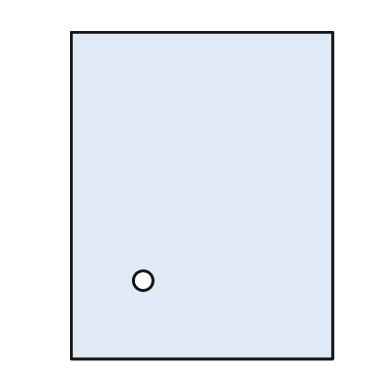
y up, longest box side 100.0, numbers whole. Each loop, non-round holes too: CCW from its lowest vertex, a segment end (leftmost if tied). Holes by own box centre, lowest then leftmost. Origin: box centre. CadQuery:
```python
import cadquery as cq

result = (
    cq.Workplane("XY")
    .moveTo(-40.0, -50.0)
    .lineTo(40.0, -50.0)
    .lineTo(40.0, 50.0)
    .lineTo(-40.0, 50.0)
    .close()
    .moveTo(-18.0, -26.0)
    .circle(3.0)
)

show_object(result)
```